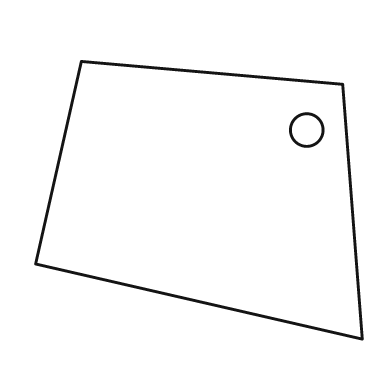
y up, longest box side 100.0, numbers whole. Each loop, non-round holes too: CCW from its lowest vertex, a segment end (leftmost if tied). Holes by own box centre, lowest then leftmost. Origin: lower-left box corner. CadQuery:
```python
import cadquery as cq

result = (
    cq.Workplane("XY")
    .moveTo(100.0, 0.0)
    .lineTo(94.0, 78.0)
    .lineTo(14.0, 85.0)
    .lineTo(0.0, 23.0)
    .close()
    .moveTo(83.0, 64.0)
    .circle(5.0)
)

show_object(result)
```